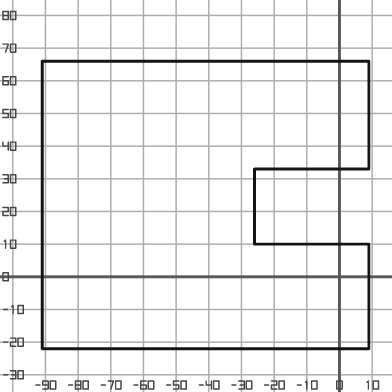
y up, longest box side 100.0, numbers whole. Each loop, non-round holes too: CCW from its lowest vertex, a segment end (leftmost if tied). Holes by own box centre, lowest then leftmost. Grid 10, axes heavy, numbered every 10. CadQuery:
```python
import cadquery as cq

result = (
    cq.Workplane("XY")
    .moveTo(-91.0, -22.0)
    .lineTo(9.0, -22.0)
    .lineTo(9.0, 10.0)
    .lineTo(-26.0, 10.0)
    .lineTo(-26.0, 33.0)
    .lineTo(9.0, 33.0)
    .lineTo(9.0, 66.0)
    .lineTo(-91.0, 66.0)
    .close()
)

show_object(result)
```